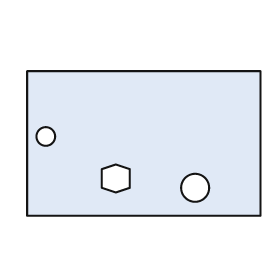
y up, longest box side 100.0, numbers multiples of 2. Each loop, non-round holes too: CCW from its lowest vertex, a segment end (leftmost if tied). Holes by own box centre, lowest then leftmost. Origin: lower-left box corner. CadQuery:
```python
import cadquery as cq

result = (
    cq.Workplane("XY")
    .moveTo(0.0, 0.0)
    .lineTo(100.0, 0.0)
    .lineTo(100.0, 62.0)
    .lineTo(0.0, 62.0)
    .close()
    .moveTo(72.0, 12.0)
    .circle(6.0)
    .moveTo(38.0, 10.0)
    .lineTo(44.0, 12.0)
    .lineTo(44.0, 20.0)
    .lineTo(38.0, 22.0)
    .lineTo(32.0, 20.0)
    .lineTo(32.0, 12.0)
    .close()
    .moveTo(8.0, 34.0)
    .circle(4.0)
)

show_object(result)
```